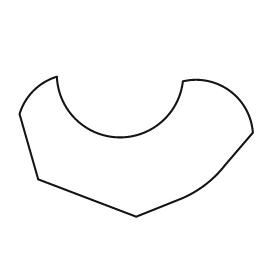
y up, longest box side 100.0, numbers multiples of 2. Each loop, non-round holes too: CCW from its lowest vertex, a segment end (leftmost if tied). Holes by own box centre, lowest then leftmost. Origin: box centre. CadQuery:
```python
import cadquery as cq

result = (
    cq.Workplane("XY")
    .moveTo(0.0, -30.0)
    .lineTo(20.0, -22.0)
    .threePointArc((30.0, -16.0), (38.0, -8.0))
    .lineTo(50.0, 6.0)
    .threePointArc((40.0, 24.0), (20.0, 28.0))
    .threePointArc((-8.0, 4.0), (-34.0, 30.0))
    .threePointArc((-44.0, 24.0), (-50.0, 14.0))
    .lineTo(-42.0, -14.0)
    .close()
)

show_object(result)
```